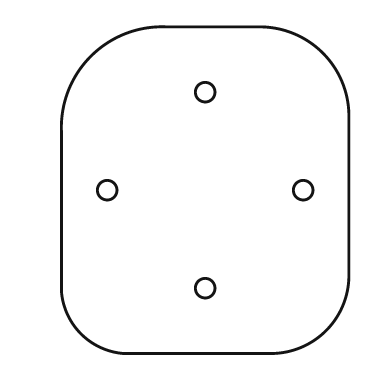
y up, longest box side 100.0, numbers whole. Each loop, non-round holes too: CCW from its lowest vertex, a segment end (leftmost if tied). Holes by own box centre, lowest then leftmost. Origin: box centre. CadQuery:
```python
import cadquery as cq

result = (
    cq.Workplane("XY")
    .moveTo(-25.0, -50.0)
    .lineTo(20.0, -50.0)
    .threePointArc((37.0, -43.0), (44.0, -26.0))
    .lineTo(44.0, 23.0)
    .threePointArc((36.0, 42.0), (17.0, 50.0))
    .lineTo(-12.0, 50.0)
    .threePointArc((-35.0, 41.0), (-44.0, 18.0))
    .lineTo(-44.0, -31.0)
    .threePointArc((-38.0, -44.0), (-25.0, -50.0))
    .close()
    .moveTo(0.0, -30.0)
    .circle(3.0)
    .moveTo(-30.0, 0.0)
    .circle(3.0)
    .moveTo(30.0, 0.0)
    .circle(3.0)
    .moveTo(0.0, 30.0)
    .circle(3.0)
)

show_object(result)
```